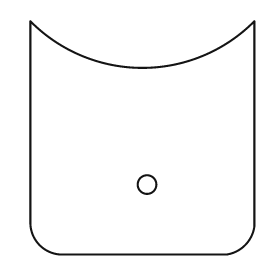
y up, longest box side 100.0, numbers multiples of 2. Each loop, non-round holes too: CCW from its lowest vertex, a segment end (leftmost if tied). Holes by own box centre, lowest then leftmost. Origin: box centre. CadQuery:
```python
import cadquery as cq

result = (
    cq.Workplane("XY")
    .moveTo(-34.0, -50.0)
    .lineTo(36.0, -50.0)
    .threePointArc((44.0, -46.0), (48.0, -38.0))
    .lineTo(48.0, 50.0)
    .threePointArc((0.0, 30.0), (-48.0, 50.0))
    .lineTo(-48.0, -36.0)
    .threePointArc((-44.0, -46.0), (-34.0, -50.0))
    .close()
    .moveTo(2.0, -20.0)
    .circle(4.0)
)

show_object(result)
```